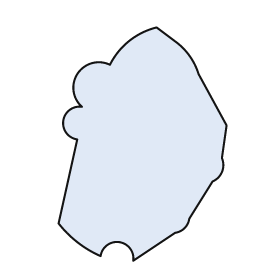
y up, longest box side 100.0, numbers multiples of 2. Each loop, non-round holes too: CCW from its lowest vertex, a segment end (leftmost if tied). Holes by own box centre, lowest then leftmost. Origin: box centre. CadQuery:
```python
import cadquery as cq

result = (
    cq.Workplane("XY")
    .moveTo(-4.0, -50.0)
    .lineTo(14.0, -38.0)
    .threePointArc((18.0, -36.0), (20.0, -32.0))
    .lineTo(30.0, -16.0)
    .threePointArc((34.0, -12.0), (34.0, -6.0))
    .lineTo(36.0, 8.0)
    .lineTo(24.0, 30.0)
    .threePointArc((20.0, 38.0), (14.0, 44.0))
    .lineTo(6.0, 50.0)
    .threePointArc((-6.0, 44.0), (-14.0, 34.0))
    .threePointArc((-28.0, 30.0), (-26.0, 16.0))
    .threePointArc((-34.0, 10.0), (-28.0, 2.0))
    .lineTo(-36.0, -34.0)
    .threePointArc((-28.0, -42.0), (-18.0, -48.0))
    .threePointArc((-10.0, -42.0), (-4.0, -50.0))
    .close()
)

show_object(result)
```